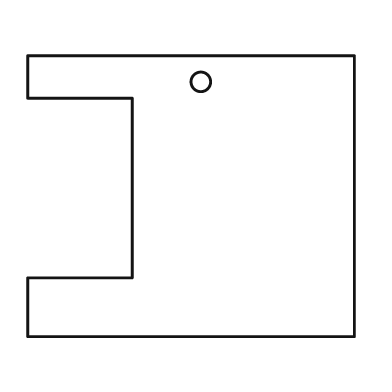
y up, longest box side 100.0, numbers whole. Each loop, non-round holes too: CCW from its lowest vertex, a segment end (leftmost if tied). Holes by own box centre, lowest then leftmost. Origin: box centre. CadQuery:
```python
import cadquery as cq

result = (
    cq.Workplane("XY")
    .moveTo(-50.0, -43.0)
    .lineTo(50.0, -43.0)
    .lineTo(50.0, 43.0)
    .lineTo(-50.0, 43.0)
    .lineTo(-50.0, 30.0)
    .lineTo(-18.0, 30.0)
    .lineTo(-18.0, -25.0)
    .lineTo(-50.0, -25.0)
    .close()
    .moveTo(3.0, 35.0)
    .circle(3.0)
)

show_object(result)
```